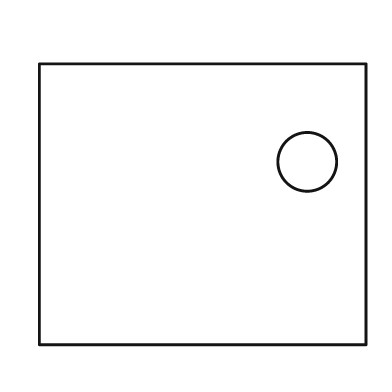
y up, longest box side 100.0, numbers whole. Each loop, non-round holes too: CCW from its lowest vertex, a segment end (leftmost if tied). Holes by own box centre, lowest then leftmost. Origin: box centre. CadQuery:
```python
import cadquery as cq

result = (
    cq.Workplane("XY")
    .moveTo(-50.0, -43.0)
    .lineTo(50.0, -43.0)
    .lineTo(50.0, 43.0)
    .lineTo(-50.0, 43.0)
    .close()
    .moveTo(32.0, 13.0)
    .circle(9.0)
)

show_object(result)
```